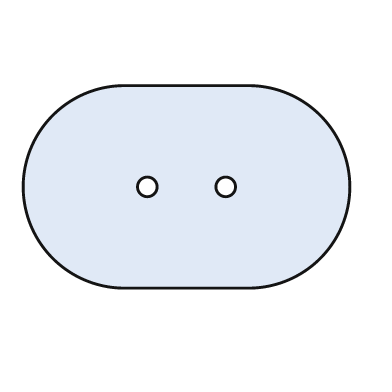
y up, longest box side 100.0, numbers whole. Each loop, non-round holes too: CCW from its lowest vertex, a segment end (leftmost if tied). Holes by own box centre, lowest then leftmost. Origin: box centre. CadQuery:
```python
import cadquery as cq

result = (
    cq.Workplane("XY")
    .moveTo(-19.0, -31.0)
    .lineTo(19.0, -31.0)
    .threePointArc((50.0, 0.0), (19.0, 31.0))
    .lineTo(-19.0, 31.0)
    .threePointArc((-50.0, 0.0), (-19.0, -31.0))
    .close()
    .moveTo(-12.0, 0.0)
    .circle(3.0)
    .moveTo(12.0, 0.0)
    .circle(3.0)
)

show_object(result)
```